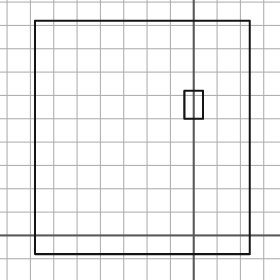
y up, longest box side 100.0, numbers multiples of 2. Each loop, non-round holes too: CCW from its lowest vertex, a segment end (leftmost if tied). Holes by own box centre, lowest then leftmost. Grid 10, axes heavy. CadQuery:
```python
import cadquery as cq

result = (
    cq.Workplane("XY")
    .moveTo(-68.0, -8.0)
    .lineTo(24.0, -8.0)
    .lineTo(24.0, 92.0)
    .lineTo(-68.0, 92.0)
    .close()
    .moveTo(-4.0, 50.0)
    .lineTo(4.0, 50.0)
    .lineTo(4.0, 62.0)
    .lineTo(-4.0, 62.0)
    .close()
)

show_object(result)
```